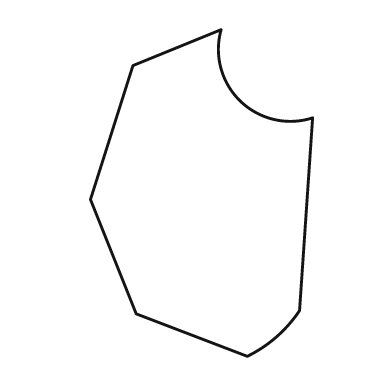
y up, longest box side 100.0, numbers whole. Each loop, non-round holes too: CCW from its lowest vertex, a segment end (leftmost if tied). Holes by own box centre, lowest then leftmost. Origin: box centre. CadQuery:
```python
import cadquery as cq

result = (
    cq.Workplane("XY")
    .moveTo(14.0, -50.0)
    .threePointArc((23.0, -44.0), (30.0, -36.0))
    .lineTo(34.0, 23.0)
    .threePointArc((12.0, 28.0), (6.0, 50.0))
    .lineTo(-21.0, 39.0)
    .lineTo(-34.0, -2.0)
    .lineTo(-20.0, -37.0)
    .close()
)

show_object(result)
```